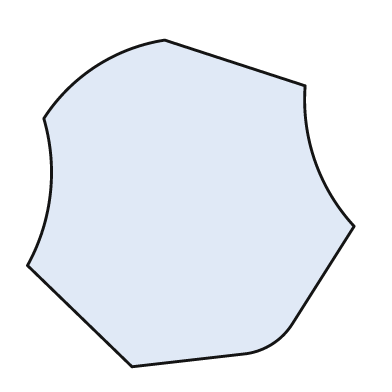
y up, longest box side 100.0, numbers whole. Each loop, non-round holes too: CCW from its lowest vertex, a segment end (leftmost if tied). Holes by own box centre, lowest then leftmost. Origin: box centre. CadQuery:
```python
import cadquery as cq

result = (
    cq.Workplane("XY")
    .moveTo(-18.0, -50.0)
    .lineTo(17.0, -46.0)
    .threePointArc((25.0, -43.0), (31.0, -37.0))
    .lineTo(50.0, -7.0)
    .threePointArc((38.0, 13.0), (35.0, 36.0))
    .lineTo(-8.0, 50.0)
    .threePointArc((-29.0, 42.0), (-45.0, 26.0))
    .threePointArc((-43.0, 3.0), (-50.0, -19.0))
    .close()
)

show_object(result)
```